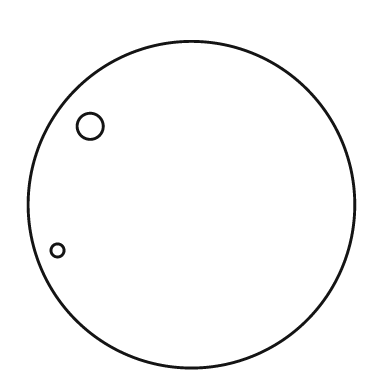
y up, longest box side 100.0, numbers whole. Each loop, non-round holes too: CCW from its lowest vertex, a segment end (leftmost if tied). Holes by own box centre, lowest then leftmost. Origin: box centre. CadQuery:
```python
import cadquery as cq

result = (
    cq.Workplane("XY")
    .moveTo(0.0, 0.0)
    .circle(50.0)
    .moveTo(-41.0, -14.0)
    .circle(2.0)
    .moveTo(-31.0, 24.0)
    .circle(4.0)
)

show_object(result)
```